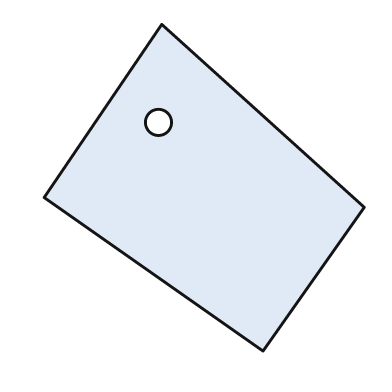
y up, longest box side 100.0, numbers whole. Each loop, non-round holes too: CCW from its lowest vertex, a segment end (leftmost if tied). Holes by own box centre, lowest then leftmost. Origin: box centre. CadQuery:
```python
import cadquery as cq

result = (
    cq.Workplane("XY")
    .moveTo(18.0, -50.0)
    .lineTo(49.0, -6.0)
    .lineTo(-13.0, 50.0)
    .lineTo(-49.0, -3.0)
    .close()
    .moveTo(-14.0, 20.0)
    .circle(4.0)
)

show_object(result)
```